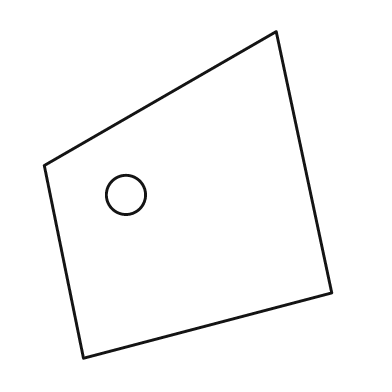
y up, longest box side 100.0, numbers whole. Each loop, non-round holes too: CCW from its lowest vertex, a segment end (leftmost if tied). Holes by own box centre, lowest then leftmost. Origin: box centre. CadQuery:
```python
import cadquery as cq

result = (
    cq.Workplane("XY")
    .moveTo(-32.0, -50.0)
    .lineTo(44.0, -30.0)
    .lineTo(27.0, 50.0)
    .lineTo(-44.0, 9.0)
    .close()
    .moveTo(-19.0, 0.0)
    .circle(6.0)
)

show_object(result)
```